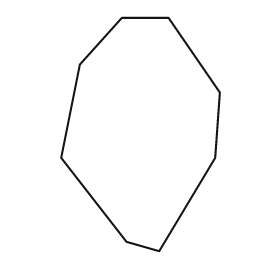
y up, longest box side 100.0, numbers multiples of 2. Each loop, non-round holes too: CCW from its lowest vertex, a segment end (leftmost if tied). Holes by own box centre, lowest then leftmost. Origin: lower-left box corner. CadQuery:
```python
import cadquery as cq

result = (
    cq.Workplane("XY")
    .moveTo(42.0, 0.0)
    .lineTo(66.0, 40.0)
    .lineTo(68.0, 68.0)
    .lineTo(46.0, 100.0)
    .lineTo(26.0, 100.0)
    .lineTo(8.0, 80.0)
    .lineTo(0.0, 40.0)
    .lineTo(28.0, 4.0)
    .close()
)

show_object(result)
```